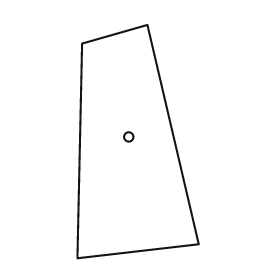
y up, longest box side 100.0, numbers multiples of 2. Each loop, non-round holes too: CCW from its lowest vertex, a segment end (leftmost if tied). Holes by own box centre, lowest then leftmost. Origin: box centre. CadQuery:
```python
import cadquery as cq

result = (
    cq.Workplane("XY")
    .moveTo(-26.0, -50.0)
    .lineTo(26.0, -44.0)
    .lineTo(4.0, 50.0)
    .lineTo(-24.0, 42.0)
    .close()
    .moveTo(-4.0, 2.0)
    .circle(2.0)
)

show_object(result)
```